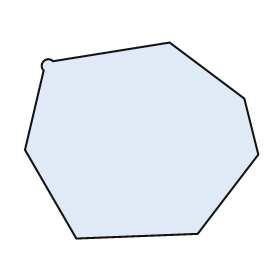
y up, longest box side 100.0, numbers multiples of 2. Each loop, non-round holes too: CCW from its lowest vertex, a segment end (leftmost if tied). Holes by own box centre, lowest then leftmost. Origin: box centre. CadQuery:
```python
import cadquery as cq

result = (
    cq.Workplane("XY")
    .moveTo(-28.0, -42.0)
    .lineTo(24.0, -40.0)
    .lineTo(50.0, -6.0)
    .lineTo(44.0, 18.0)
    .lineTo(12.0, 42.0)
    .lineTo(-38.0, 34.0)
    .threePointArc((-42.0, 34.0), (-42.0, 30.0))
    .lineTo(-50.0, -4.0)
    .close()
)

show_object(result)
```